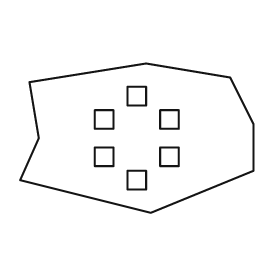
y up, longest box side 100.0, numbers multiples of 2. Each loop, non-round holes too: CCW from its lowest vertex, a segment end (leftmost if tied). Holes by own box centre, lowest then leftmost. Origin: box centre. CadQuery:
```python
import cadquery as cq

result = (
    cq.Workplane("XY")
    .moveTo(6.0, -32.0)
    .lineTo(50.0, -14.0)
    .lineTo(50.0, 6.0)
    .lineTo(40.0, 26.0)
    .lineTo(4.0, 32.0)
    .lineTo(-46.0, 24.0)
    .lineTo(-42.0, 0.0)
    .lineTo(-50.0, -18.0)
    .close()
    .moveTo(-4.0, -22.0)
    .lineTo(4.0, -22.0)
    .lineTo(4.0, -14.0)
    .lineTo(-4.0, -14.0)
    .close()
    .moveTo(-18.0, -12.0)
    .lineTo(-10.0, -12.0)
    .lineTo(-10.0, -4.0)
    .lineTo(-18.0, -4.0)
    .close()
    .moveTo(10.0, -12.0)
    .lineTo(18.0, -12.0)
    .lineTo(18.0, -4.0)
    .lineTo(10.0, -4.0)
    .close()
    .moveTo(-18.0, 4.0)
    .lineTo(-10.0, 4.0)
    .lineTo(-10.0, 12.0)
    .lineTo(-18.0, 12.0)
    .close()
    .moveTo(10.0, 4.0)
    .lineTo(18.0, 4.0)
    .lineTo(18.0, 12.0)
    .lineTo(10.0, 12.0)
    .close()
    .moveTo(-4.0, 14.0)
    .lineTo(4.0, 14.0)
    .lineTo(4.0, 22.0)
    .lineTo(-4.0, 22.0)
    .close()
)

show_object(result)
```